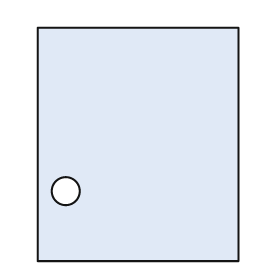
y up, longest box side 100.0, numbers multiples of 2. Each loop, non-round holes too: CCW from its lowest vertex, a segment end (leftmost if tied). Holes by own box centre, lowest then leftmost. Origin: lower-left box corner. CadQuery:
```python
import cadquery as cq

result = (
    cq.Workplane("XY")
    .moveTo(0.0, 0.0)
    .lineTo(86.0, 0.0)
    .lineTo(86.0, 100.0)
    .lineTo(0.0, 100.0)
    .close()
    .moveTo(12.0, 30.0)
    .circle(6.0)
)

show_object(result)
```